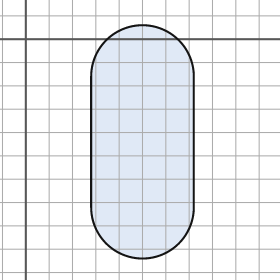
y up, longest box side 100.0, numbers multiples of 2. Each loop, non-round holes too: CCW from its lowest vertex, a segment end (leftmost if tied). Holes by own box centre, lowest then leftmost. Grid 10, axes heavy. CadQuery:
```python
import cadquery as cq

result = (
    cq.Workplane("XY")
    .moveTo(28.0, -72.0)
    .threePointArc((50.0, -94.0), (72.0, -72.0))
    .lineTo(72.0, -16.0)
    .threePointArc((50.0, 6.0), (28.0, -16.0))
    .close()
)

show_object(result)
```